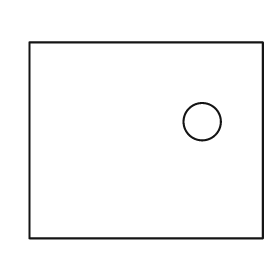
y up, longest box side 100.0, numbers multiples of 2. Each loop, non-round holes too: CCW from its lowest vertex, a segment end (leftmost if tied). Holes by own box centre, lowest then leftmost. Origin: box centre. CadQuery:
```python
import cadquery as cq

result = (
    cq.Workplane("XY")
    .moveTo(-50.0, -42.0)
    .lineTo(50.0, -42.0)
    .lineTo(50.0, 42.0)
    .lineTo(-50.0, 42.0)
    .close()
    .moveTo(24.0, 8.0)
    .circle(8.0)
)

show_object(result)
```